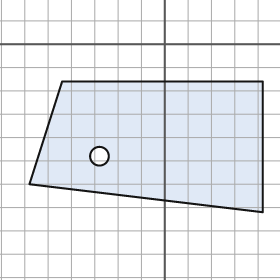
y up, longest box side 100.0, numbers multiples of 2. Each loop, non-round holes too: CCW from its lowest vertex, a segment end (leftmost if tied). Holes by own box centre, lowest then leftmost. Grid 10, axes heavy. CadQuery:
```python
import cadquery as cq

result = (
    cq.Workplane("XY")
    .moveTo(42.0, -72.0)
    .lineTo(42.0, -16.0)
    .lineTo(-44.0, -16.0)
    .lineTo(-58.0, -60.0)
    .close()
    .moveTo(-28.0, -48.0)
    .circle(4.0)
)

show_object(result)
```